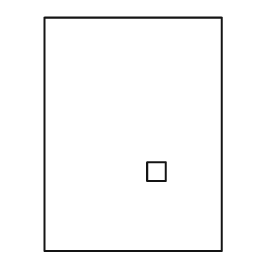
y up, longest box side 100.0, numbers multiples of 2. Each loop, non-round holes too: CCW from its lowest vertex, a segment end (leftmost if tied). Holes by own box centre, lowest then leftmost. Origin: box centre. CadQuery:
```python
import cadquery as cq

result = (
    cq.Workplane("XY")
    .moveTo(-38.0, -50.0)
    .lineTo(38.0, -50.0)
    .lineTo(38.0, 50.0)
    .lineTo(-38.0, 50.0)
    .close()
    .moveTo(6.0, -20.0)
    .lineTo(14.0, -20.0)
    .lineTo(14.0, -12.0)
    .lineTo(6.0, -12.0)
    .close()
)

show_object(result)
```